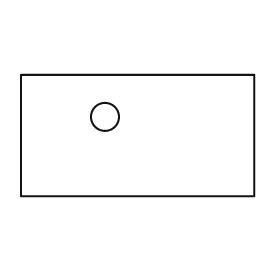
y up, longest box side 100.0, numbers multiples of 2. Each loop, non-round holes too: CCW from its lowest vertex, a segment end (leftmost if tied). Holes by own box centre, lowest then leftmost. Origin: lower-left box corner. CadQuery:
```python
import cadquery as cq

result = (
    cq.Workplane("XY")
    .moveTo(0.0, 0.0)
    .lineTo(100.0, 0.0)
    .lineTo(100.0, 52.0)
    .lineTo(0.0, 52.0)
    .close()
    .moveTo(36.0, 34.0)
    .circle(6.0)
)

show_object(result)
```